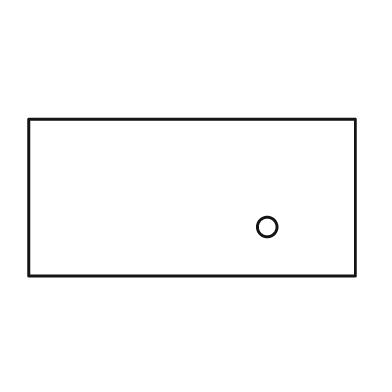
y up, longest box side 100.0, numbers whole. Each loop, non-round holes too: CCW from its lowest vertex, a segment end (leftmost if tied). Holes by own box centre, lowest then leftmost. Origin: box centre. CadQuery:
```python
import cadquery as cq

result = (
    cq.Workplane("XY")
    .moveTo(-50.0, -24.0)
    .lineTo(50.0, -24.0)
    .lineTo(50.0, 24.0)
    .lineTo(-50.0, 24.0)
    .close()
    .moveTo(23.0, -9.0)
    .circle(3.0)
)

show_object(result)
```